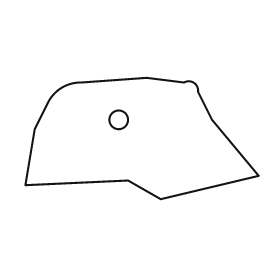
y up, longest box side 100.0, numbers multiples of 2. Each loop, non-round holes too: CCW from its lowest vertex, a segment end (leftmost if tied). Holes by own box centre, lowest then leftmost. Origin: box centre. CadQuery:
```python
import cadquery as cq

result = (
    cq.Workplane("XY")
    .moveTo(8.0, -26.0)
    .lineTo(50.0, -16.0)
    .lineTo(30.0, 8.0)
    .lineTo(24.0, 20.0)
    .threePointArc((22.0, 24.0), (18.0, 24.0))
    .lineTo(2.0, 26.0)
    .lineTo(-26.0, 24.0)
    .threePointArc((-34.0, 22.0), (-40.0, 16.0))
    .lineTo(-46.0, 4.0)
    .lineTo(-50.0, -20.0)
    .lineTo(-6.0, -18.0)
    .close()
    .moveTo(-10.0, 8.0)
    .circle(4.0)
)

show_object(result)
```